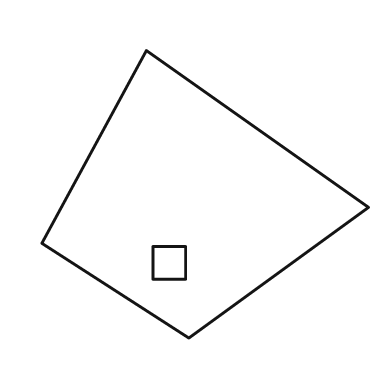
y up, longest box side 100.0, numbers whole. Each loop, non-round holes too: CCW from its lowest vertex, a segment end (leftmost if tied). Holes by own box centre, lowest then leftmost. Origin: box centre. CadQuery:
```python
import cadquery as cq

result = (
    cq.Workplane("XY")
    .moveTo(-5.0, -44.0)
    .lineTo(50.0, -4.0)
    .lineTo(-18.0, 44.0)
    .lineTo(-50.0, -15.0)
    .close()
    .moveTo(-16.0, -26.0)
    .lineTo(-6.0, -26.0)
    .lineTo(-6.0, -16.0)
    .lineTo(-16.0, -16.0)
    .close()
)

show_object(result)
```